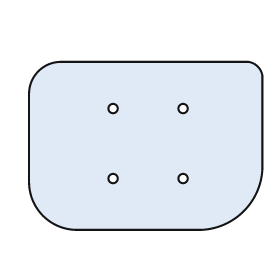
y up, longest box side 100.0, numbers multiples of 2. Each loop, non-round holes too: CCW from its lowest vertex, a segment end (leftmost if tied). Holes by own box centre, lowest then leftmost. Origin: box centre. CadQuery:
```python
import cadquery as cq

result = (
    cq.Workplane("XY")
    .moveTo(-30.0, -36.0)
    .lineTo(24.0, -36.0)
    .threePointArc((42.0, -28.0), (50.0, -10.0))
    .lineTo(50.0, 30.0)
    .threePointArc((48.0, 34.0), (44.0, 36.0))
    .lineTo(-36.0, 36.0)
    .threePointArc((-46.0, 32.0), (-50.0, 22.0))
    .lineTo(-50.0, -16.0)
    .threePointArc((-44.0, -30.0), (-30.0, -36.0))
    .close()
    .moveTo(-14.0, -14.0)
    .circle(2.0)
    .moveTo(16.0, -14.0)
    .circle(2.0)
    .moveTo(-14.0, 16.0)
    .circle(2.0)
    .moveTo(16.0, 16.0)
    .circle(2.0)
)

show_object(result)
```